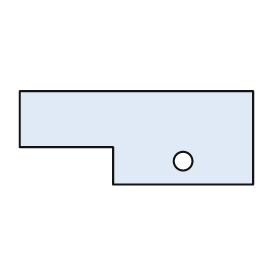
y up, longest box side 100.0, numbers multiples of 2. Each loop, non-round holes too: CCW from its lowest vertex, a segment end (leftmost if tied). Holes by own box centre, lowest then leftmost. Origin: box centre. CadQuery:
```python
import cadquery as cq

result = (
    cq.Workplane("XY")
    .moveTo(-10.0, -20.0)
    .lineTo(50.0, -20.0)
    .lineTo(50.0, 20.0)
    .lineTo(-50.0, 20.0)
    .lineTo(-50.0, -4.0)
    .lineTo(-10.0, -4.0)
    .close()
    .moveTo(20.0, -10.0)
    .circle(4.0)
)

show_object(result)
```